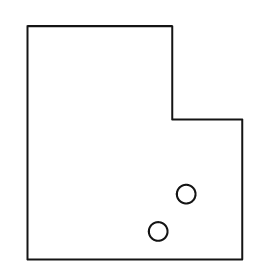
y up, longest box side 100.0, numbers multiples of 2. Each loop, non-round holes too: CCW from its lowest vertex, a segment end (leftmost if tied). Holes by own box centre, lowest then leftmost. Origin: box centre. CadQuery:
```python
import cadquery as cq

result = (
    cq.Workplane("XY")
    .moveTo(-46.0, -50.0)
    .lineTo(46.0, -50.0)
    .lineTo(46.0, 10.0)
    .lineTo(16.0, 10.0)
    .lineTo(16.0, 50.0)
    .lineTo(-46.0, 50.0)
    .close()
    .moveTo(10.0, -38.0)
    .circle(4.0)
    .moveTo(22.0, -22.0)
    .circle(4.0)
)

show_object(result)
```